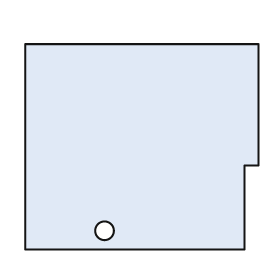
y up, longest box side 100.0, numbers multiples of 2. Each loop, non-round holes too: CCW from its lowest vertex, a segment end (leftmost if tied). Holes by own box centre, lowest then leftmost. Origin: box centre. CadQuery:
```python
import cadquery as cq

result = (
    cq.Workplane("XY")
    .moveTo(-50.0, -44.0)
    .lineTo(44.0, -44.0)
    .lineTo(44.0, -8.0)
    .lineTo(50.0, -8.0)
    .lineTo(50.0, 44.0)
    .lineTo(-50.0, 44.0)
    .close()
    .moveTo(-16.0, -36.0)
    .circle(4.0)
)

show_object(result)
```